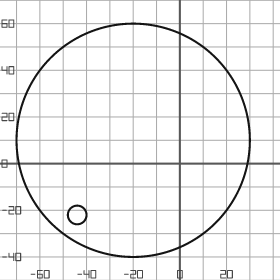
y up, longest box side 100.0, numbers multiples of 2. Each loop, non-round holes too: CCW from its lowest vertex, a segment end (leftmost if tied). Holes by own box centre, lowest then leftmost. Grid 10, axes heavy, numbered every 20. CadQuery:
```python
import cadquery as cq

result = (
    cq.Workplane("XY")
    .moveTo(-20.0, 10.0)
    .circle(50.0)
    .moveTo(-44.0, -22.0)
    .circle(4.0)
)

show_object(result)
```